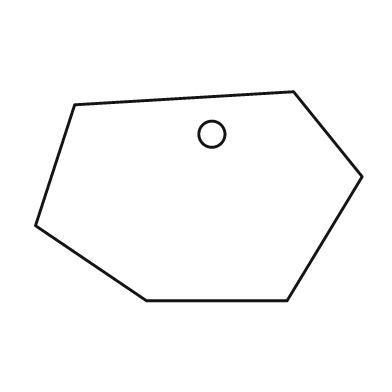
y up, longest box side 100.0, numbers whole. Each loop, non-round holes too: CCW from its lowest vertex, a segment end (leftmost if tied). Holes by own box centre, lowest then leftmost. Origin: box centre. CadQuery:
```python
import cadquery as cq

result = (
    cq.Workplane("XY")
    .moveTo(-16.0, -32.0)
    .lineTo(27.0, -32.0)
    .lineTo(50.0, 6.0)
    .lineTo(29.0, 32.0)
    .lineTo(-38.0, 28.0)
    .lineTo(-50.0, -9.0)
    .close()
    .moveTo(4.0, 19.0)
    .circle(4.0)
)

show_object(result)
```